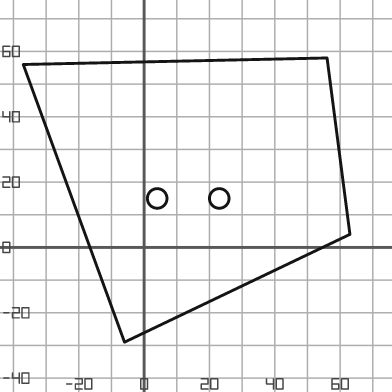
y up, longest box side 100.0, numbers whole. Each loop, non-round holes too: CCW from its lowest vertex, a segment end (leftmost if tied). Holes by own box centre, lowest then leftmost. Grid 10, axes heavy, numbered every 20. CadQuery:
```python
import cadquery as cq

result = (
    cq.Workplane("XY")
    .moveTo(-6.0, -29.0)
    .lineTo(63.0, 4.0)
    .lineTo(56.0, 58.0)
    .lineTo(-37.0, 56.0)
    .close()
    .moveTo(4.0, 15.0)
    .circle(3.0)
    .moveTo(23.0, 15.0)
    .circle(3.0)
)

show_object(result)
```